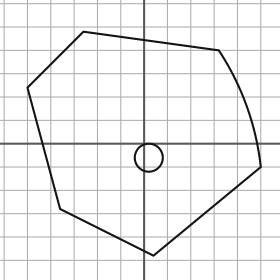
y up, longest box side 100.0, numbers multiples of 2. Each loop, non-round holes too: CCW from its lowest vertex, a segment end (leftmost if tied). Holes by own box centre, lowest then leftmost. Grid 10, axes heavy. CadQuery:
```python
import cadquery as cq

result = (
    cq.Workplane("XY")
    .moveTo(4.0, -48.0)
    .lineTo(50.0, -10.0)
    .threePointArc((44.0, 16.0), (32.0, 40.0))
    .lineTo(-26.0, 48.0)
    .lineTo(-50.0, 24.0)
    .lineTo(-36.0, -28.0)
    .close()
    .moveTo(2.0, -6.0)
    .circle(6.0)
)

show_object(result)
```